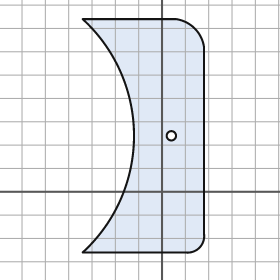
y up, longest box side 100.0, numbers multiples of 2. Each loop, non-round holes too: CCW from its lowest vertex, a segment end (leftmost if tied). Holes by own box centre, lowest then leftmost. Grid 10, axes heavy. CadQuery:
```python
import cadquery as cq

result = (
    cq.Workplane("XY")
    .moveTo(-34.0, -26.0)
    .lineTo(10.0, -26.0)
    .threePointArc((16.0, -24.0), (18.0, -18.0))
    .lineTo(18.0, 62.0)
    .threePointArc((14.0, 70.0), (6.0, 74.0))
    .lineTo(-34.0, 74.0)
    .threePointArc((-12.0, 24.0), (-34.0, -26.0))
    .close()
    .moveTo(4.0, 24.0)
    .circle(2.0)
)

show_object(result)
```